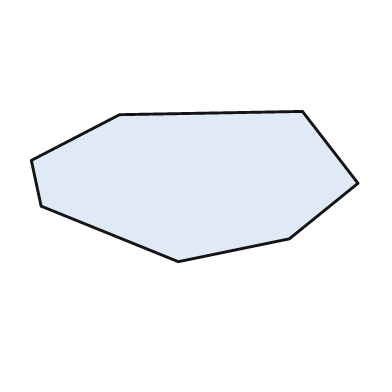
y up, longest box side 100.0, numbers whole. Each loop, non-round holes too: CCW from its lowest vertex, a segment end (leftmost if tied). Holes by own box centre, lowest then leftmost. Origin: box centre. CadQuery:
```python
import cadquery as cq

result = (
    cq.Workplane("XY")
    .moveTo(-5.0, -23.0)
    .lineTo(29.0, -16.0)
    .lineTo(50.0, 1.0)
    .lineTo(33.0, 23.0)
    .lineTo(-23.0, 22.0)
    .lineTo(-50.0, 8.0)
    .lineTo(-47.0, -6.0)
    .close()
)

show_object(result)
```